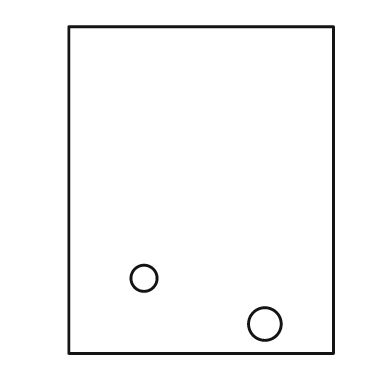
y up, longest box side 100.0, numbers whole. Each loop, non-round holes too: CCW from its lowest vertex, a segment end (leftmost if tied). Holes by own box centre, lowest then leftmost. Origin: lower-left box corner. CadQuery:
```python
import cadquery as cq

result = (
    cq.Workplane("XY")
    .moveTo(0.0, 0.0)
    .lineTo(81.0, 0.0)
    .lineTo(81.0, 100.0)
    .lineTo(0.0, 100.0)
    .close()
    .moveTo(60.0, 9.0)
    .circle(5.0)
    .moveTo(23.0, 23.0)
    .circle(4.0)
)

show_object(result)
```